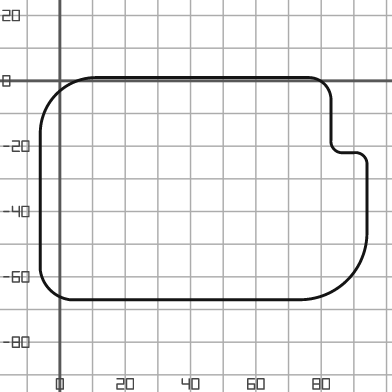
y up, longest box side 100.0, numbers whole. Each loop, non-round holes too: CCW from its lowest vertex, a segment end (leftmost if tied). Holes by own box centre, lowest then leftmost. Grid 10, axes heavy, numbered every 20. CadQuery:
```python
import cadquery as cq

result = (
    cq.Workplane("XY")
    .moveTo(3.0, -67.0)
    .lineTo(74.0, -67.0)
    .threePointArc((88.0, -61.0), (94.0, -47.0))
    .lineTo(94.0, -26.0)
    .threePointArc((93.0, -23.0), (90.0, -22.0))
    .lineTo(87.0, -22.0)
    .threePointArc((84.0, -21.0), (83.0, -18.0))
    .lineTo(83.0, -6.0)
    .threePointArc((81.0, -1.0), (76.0, 1.0))
    .lineTo(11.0, 1.0)
    .threePointArc((-1.0, -4.0), (-6.0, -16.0))
    .lineTo(-6.0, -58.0)
    .threePointArc((-3.0, -64.0), (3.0, -67.0))
    .close()
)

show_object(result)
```